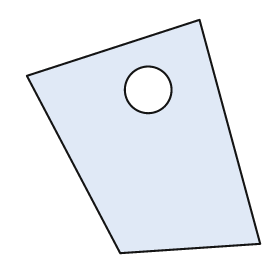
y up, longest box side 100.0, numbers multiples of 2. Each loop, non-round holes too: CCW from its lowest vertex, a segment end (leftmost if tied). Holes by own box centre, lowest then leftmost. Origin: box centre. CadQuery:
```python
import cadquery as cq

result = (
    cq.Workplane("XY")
    .moveTo(-10.0, -50.0)
    .lineTo(50.0, -46.0)
    .lineTo(24.0, 50.0)
    .lineTo(-50.0, 26.0)
    .close()
    .moveTo(2.0, 20.0)
    .circle(10.0)
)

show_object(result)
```